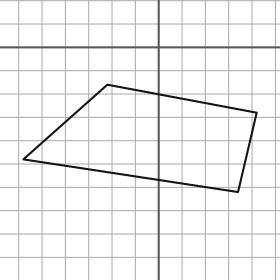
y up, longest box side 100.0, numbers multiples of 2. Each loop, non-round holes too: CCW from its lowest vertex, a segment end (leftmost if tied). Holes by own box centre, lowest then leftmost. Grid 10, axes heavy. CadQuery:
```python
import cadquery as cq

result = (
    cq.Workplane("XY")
    .moveTo(34.0, -62.0)
    .lineTo(42.0, -28.0)
    .lineTo(-22.0, -16.0)
    .lineTo(-58.0, -48.0)
    .close()
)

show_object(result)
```